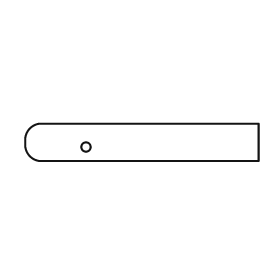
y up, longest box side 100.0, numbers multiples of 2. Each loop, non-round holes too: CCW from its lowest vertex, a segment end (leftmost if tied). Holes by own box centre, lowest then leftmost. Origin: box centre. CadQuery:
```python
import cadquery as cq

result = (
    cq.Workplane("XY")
    .moveTo(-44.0, -8.0)
    .lineTo(50.0, -8.0)
    .lineTo(50.0, 8.0)
    .lineTo(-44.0, 8.0)
    .threePointArc((-48.0, 6.0), (-50.0, 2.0))
    .lineTo(-50.0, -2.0)
    .threePointArc((-48.0, -6.0), (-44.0, -8.0))
    .close()
    .moveTo(-24.0, -2.0)
    .circle(2.0)
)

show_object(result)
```